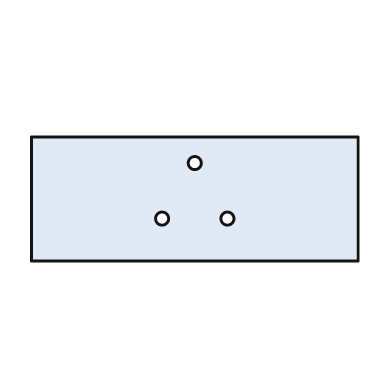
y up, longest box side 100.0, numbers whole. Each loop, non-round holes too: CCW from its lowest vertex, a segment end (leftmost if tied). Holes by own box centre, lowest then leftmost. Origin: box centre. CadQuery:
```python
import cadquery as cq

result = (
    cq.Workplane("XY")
    .moveTo(-50.0, -19.0)
    .lineTo(50.0, -19.0)
    .lineTo(50.0, 19.0)
    .lineTo(-50.0, 19.0)
    .close()
    .moveTo(-10.0, -6.0)
    .circle(2.0)
    .moveTo(10.0, -6.0)
    .circle(2.0)
    .moveTo(0.0, 11.0)
    .circle(2.0)
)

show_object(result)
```